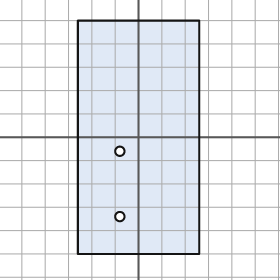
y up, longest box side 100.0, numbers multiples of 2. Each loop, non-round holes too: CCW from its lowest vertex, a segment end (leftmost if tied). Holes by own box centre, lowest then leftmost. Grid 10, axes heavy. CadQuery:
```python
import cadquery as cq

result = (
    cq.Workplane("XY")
    .moveTo(-26.0, -50.0)
    .lineTo(26.0, -50.0)
    .lineTo(26.0, 50.0)
    .lineTo(-26.0, 50.0)
    .close()
    .moveTo(-8.0, -34.0)
    .circle(2.0)
    .moveTo(-8.0, -6.0)
    .circle(2.0)
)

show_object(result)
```